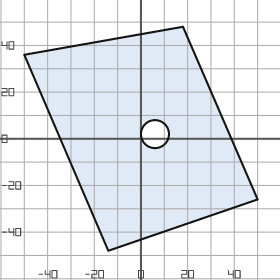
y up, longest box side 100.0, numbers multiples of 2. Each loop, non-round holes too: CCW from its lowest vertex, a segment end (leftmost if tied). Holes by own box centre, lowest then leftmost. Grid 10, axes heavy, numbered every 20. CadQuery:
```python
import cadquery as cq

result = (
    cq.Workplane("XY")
    .moveTo(-14.0, -48.0)
    .lineTo(50.0, -26.0)
    .lineTo(18.0, 48.0)
    .lineTo(-50.0, 36.0)
    .close()
    .moveTo(6.0, 2.0)
    .circle(6.0)
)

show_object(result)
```